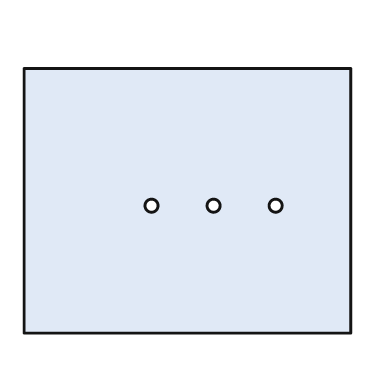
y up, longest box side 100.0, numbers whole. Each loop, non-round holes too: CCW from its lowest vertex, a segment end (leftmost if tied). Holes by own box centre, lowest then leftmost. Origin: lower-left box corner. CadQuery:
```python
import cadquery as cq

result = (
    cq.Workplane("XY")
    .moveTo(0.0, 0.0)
    .lineTo(100.0, 0.0)
    .lineTo(100.0, 81.0)
    .lineTo(0.0, 81.0)
    .close()
    .moveTo(39.0, 39.0)
    .circle(2.0)
    .moveTo(58.0, 39.0)
    .circle(2.0)
    .moveTo(77.0, 39.0)
    .circle(2.0)
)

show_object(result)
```